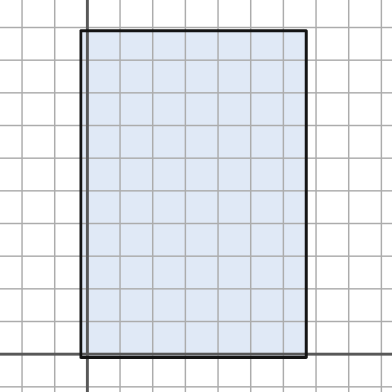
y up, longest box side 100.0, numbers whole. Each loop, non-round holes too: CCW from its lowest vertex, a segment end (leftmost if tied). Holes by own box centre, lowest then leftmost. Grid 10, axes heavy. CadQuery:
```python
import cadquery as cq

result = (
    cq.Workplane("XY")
    .moveTo(-2.0, -1.0)
    .lineTo(67.0, -1.0)
    .lineTo(67.0, 99.0)
    .lineTo(-2.0, 99.0)
    .close()
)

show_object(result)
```